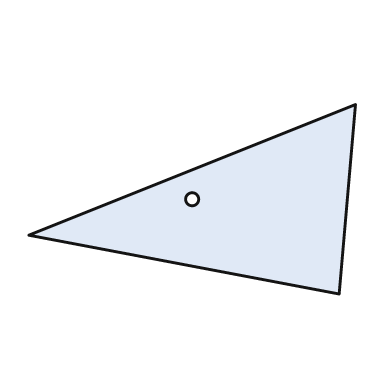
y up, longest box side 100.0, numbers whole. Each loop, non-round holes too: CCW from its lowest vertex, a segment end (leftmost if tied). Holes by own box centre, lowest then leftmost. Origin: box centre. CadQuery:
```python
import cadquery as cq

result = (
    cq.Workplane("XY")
    .moveTo(45.0, -29.0)
    .lineTo(50.0, 29.0)
    .lineTo(-50.0, -11.0)
    .close()
    .moveTo(0.0, 0.0)
    .circle(2.0)
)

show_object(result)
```